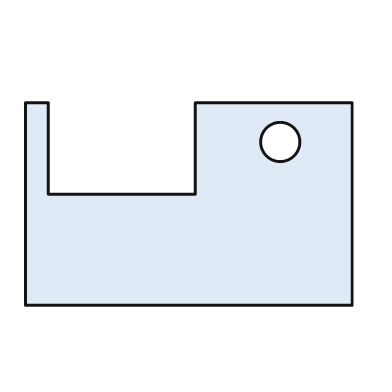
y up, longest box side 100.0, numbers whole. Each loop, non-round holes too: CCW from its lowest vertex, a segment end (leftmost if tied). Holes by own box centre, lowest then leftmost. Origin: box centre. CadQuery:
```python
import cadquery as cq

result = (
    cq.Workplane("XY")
    .moveTo(-50.0, -31.0)
    .lineTo(50.0, -31.0)
    .lineTo(50.0, 31.0)
    .lineTo(2.0, 31.0)
    .lineTo(2.0, 3.0)
    .lineTo(-43.0, 3.0)
    .lineTo(-43.0, 31.0)
    .lineTo(-50.0, 31.0)
    .close()
    .moveTo(28.0, 19.0)
    .circle(6.0)
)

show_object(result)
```